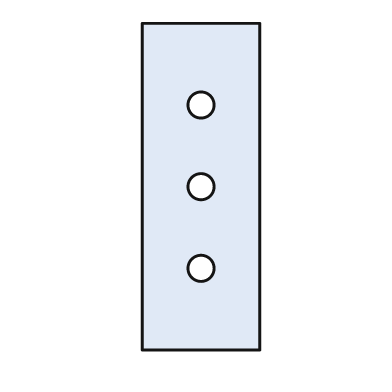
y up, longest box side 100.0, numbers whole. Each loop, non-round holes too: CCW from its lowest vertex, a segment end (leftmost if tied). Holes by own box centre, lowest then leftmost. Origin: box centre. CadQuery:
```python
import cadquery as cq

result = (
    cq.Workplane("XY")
    .moveTo(-18.0, -50.0)
    .lineTo(18.0, -50.0)
    .lineTo(18.0, 50.0)
    .lineTo(-18.0, 50.0)
    .close()
    .moveTo(0.0, -25.0)
    .circle(4.0)
    .moveTo(0.0, 0.0)
    .circle(4.0)
    .moveTo(0.0, 25.0)
    .circle(4.0)
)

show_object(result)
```